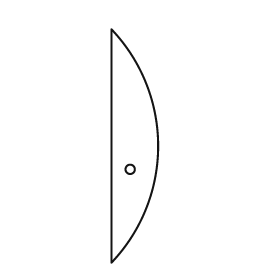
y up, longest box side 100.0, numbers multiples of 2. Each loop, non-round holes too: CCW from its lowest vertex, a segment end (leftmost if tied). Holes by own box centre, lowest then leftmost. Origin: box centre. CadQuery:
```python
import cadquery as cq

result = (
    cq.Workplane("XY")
    .moveTo(-10.0, -50.0)
    .threePointArc((10.0, 0.0), (-10.0, 50.0))
    .close()
    .moveTo(-2.0, -10.0)
    .circle(2.0)
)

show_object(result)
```